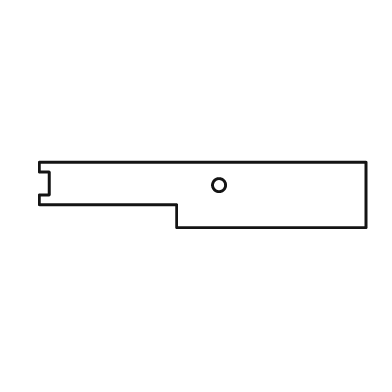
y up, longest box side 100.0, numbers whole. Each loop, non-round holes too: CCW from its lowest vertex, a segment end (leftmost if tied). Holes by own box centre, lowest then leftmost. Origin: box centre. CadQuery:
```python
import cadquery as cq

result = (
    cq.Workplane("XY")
    .moveTo(-8.0, -10.0)
    .lineTo(50.0, -10.0)
    .lineTo(50.0, 10.0)
    .lineTo(-50.0, 10.0)
    .lineTo(-50.0, 7.0)
    .lineTo(-47.0, 7.0)
    .lineTo(-47.0, 0.0)
    .lineTo(-50.0, 0.0)
    .lineTo(-50.0, -3.0)
    .lineTo(-8.0, -3.0)
    .close()
    .moveTo(5.0, 3.0)
    .circle(2.0)
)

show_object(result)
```